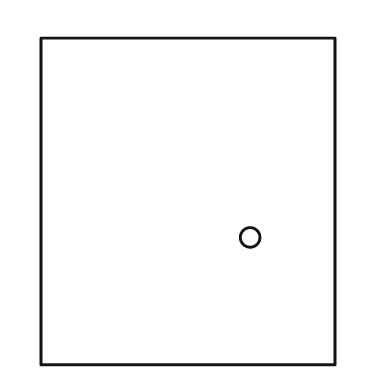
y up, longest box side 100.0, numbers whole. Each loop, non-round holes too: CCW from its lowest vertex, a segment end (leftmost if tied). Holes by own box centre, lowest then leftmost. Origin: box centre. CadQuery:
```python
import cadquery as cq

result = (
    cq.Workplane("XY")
    .moveTo(-45.0, -50.0)
    .lineTo(45.0, -50.0)
    .lineTo(45.0, 50.0)
    .lineTo(-45.0, 50.0)
    .close()
    .moveTo(19.0, -11.0)
    .circle(3.0)
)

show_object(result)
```